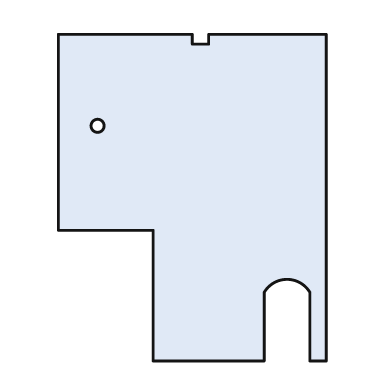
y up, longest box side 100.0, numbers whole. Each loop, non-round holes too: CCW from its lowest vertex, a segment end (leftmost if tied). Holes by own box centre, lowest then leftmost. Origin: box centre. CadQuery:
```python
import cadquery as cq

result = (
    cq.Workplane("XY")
    .moveTo(-12.0, -50.0)
    .lineTo(22.0, -50.0)
    .lineTo(22.0, -29.0)
    .threePointArc((29.0, -25.0), (36.0, -29.0))
    .lineTo(36.0, -50.0)
    .lineTo(41.0, -50.0)
    .lineTo(41.0, 50.0)
    .lineTo(5.0, 50.0)
    .lineTo(5.0, 47.0)
    .lineTo(0.0, 47.0)
    .lineTo(0.0, 50.0)
    .lineTo(-41.0, 50.0)
    .lineTo(-41.0, -10.0)
    .lineTo(-12.0, -10.0)
    .close()
    .moveTo(-29.0, 22.0)
    .circle(2.0)
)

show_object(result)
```